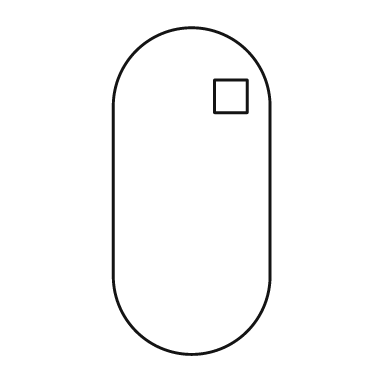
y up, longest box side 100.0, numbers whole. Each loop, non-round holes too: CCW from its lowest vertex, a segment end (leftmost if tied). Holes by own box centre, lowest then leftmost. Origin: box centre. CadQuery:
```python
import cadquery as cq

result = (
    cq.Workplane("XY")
    .moveTo(-24.0, -26.0)
    .threePointArc((0.0, -50.0), (24.0, -26.0))
    .lineTo(24.0, 26.0)
    .threePointArc((0.0, 50.0), (-24.0, 26.0))
    .close()
    .moveTo(7.0, 24.0)
    .lineTo(17.0, 24.0)
    .lineTo(17.0, 34.0)
    .lineTo(7.0, 34.0)
    .close()
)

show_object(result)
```